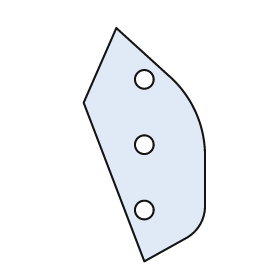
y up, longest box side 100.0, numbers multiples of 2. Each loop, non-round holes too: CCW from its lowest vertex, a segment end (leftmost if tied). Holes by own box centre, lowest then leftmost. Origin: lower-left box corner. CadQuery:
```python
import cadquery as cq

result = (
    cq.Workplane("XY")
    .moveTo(26.0, 0.0)
    .lineTo(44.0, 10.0)
    .threePointArc((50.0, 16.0), (52.0, 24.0))
    .lineTo(52.0, 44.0)
    .threePointArc((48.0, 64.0), (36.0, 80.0))
    .lineTo(14.0, 100.0)
    .lineTo(0.0, 68.0)
    .close()
    .moveTo(26.0, 22.0)
    .circle(4.0)
    .moveTo(26.0, 50.0)
    .circle(4.0)
    .moveTo(26.0, 78.0)
    .circle(4.0)
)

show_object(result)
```